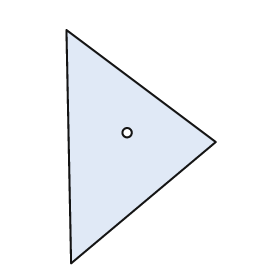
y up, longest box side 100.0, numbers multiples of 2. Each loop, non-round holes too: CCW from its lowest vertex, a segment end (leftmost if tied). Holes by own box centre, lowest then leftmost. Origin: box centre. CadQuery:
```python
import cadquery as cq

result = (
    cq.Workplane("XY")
    .moveTo(-30.0, -50.0)
    .lineTo(32.0, 2.0)
    .lineTo(-32.0, 50.0)
    .close()
    .moveTo(-6.0, 6.0)
    .circle(2.0)
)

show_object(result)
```